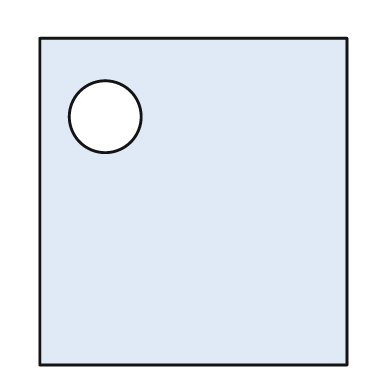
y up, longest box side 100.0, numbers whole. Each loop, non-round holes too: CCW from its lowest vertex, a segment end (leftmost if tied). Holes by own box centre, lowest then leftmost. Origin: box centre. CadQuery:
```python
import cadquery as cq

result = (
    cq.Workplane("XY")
    .moveTo(-47.0, -50.0)
    .lineTo(47.0, -50.0)
    .lineTo(47.0, 50.0)
    .lineTo(-47.0, 50.0)
    .close()
    .moveTo(-27.0, 26.0)
    .circle(11.0)
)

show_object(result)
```